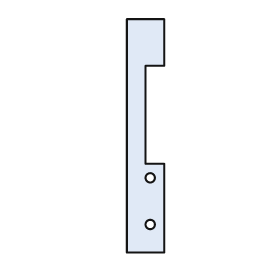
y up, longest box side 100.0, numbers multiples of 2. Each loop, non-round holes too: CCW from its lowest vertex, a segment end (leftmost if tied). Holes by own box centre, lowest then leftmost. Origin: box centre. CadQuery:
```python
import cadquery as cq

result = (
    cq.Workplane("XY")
    .moveTo(-8.0, -50.0)
    .lineTo(8.0, -50.0)
    .lineTo(8.0, -12.0)
    .lineTo(0.0, -12.0)
    .lineTo(0.0, 30.0)
    .lineTo(8.0, 30.0)
    .lineTo(8.0, 50.0)
    .lineTo(-8.0, 50.0)
    .close()
    .moveTo(2.0, -38.0)
    .circle(2.0)
    .moveTo(2.0, -18.0)
    .circle(2.0)
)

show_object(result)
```